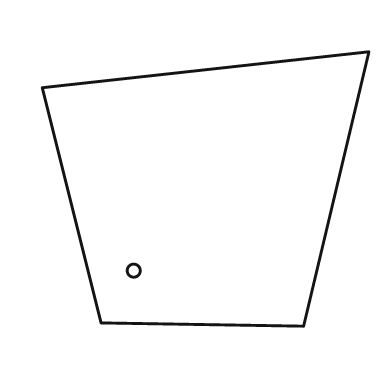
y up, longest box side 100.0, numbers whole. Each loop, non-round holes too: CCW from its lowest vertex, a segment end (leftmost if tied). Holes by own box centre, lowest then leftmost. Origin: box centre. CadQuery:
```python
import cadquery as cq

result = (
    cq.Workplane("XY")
    .moveTo(30.0, -42.0)
    .lineTo(50.0, 42.0)
    .lineTo(-50.0, 31.0)
    .lineTo(-32.0, -41.0)
    .close()
    .moveTo(-22.0, -25.0)
    .circle(2.0)
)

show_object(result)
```